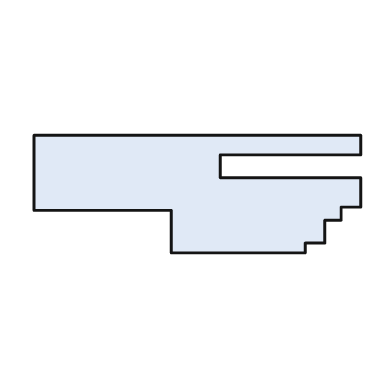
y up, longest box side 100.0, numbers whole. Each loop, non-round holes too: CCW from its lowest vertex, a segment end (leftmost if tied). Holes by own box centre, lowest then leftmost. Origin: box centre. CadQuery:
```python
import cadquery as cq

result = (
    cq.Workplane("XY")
    .moveTo(-8.0, -18.0)
    .lineTo(33.0, -18.0)
    .lineTo(33.0, -15.0)
    .lineTo(39.0, -15.0)
    .lineTo(39.0, -8.0)
    .lineTo(44.0, -8.0)
    .lineTo(44.0, -4.0)
    .lineTo(50.0, -4.0)
    .lineTo(50.0, 5.0)
    .lineTo(7.0, 5.0)
    .lineTo(7.0, 12.0)
    .lineTo(50.0, 12.0)
    .lineTo(50.0, 18.0)
    .lineTo(-50.0, 18.0)
    .lineTo(-50.0, -5.0)
    .lineTo(-8.0, -5.0)
    .close()
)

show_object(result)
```